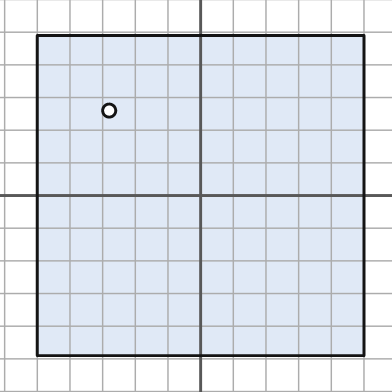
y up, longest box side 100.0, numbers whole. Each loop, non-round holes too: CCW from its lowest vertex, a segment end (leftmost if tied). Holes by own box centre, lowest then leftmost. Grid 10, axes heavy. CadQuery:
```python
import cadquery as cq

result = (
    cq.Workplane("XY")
    .moveTo(-50.0, -49.0)
    .lineTo(50.0, -49.0)
    .lineTo(50.0, 49.0)
    .lineTo(-50.0, 49.0)
    .close()
    .moveTo(-28.0, 26.0)
    .circle(2.0)
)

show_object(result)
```